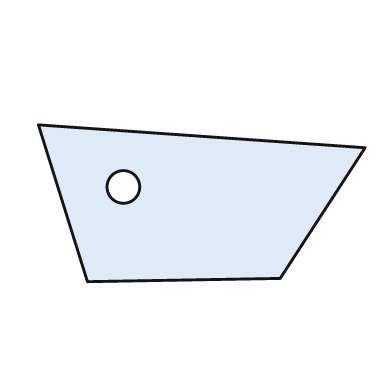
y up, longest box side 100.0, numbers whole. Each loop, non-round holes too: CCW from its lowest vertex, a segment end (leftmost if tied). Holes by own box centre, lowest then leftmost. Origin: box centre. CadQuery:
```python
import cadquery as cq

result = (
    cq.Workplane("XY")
    .moveTo(-35.0, -24.0)
    .lineTo(24.0, -23.0)
    .lineTo(50.0, 17.0)
    .lineTo(-50.0, 24.0)
    .close()
    .moveTo(-24.0, 5.0)
    .circle(5.0)
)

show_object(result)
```